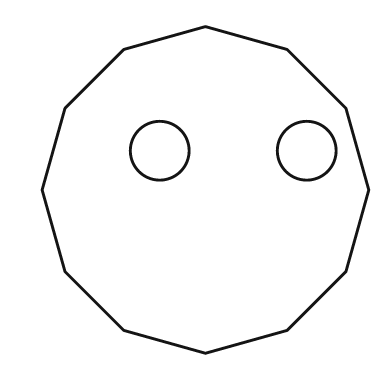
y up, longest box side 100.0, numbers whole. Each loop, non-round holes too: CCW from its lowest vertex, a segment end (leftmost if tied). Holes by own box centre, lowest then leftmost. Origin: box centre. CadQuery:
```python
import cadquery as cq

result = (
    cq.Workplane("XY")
    .moveTo(0.0, -50.0)
    .lineTo(25.0, -43.0)
    .lineTo(43.0, -25.0)
    .lineTo(50.0, 0.0)
    .lineTo(43.0, 25.0)
    .lineTo(25.0, 43.0)
    .lineTo(0.0, 50.0)
    .lineTo(-25.0, 43.0)
    .lineTo(-43.0, 25.0)
    .lineTo(-50.0, 0.0)
    .lineTo(-43.0, -25.0)
    .lineTo(-25.0, -43.0)
    .close()
    .moveTo(-14.0, 12.0)
    .circle(9.0)
    .moveTo(31.0, 12.0)
    .circle(9.0)
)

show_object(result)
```